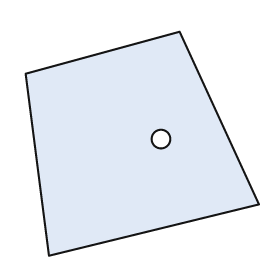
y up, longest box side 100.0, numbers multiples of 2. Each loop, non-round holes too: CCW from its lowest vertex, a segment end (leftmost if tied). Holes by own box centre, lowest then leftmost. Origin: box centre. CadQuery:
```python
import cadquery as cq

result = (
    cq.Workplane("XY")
    .moveTo(-40.0, -48.0)
    .lineTo(50.0, -26.0)
    .lineTo(16.0, 48.0)
    .lineTo(-50.0, 30.0)
    .close()
    .moveTo(8.0, 2.0)
    .circle(4.0)
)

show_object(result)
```